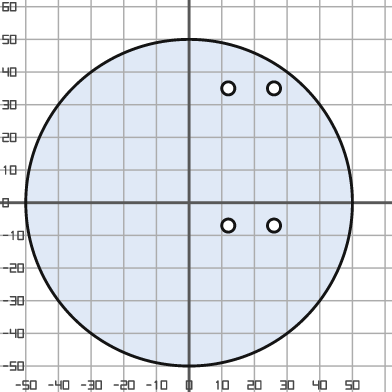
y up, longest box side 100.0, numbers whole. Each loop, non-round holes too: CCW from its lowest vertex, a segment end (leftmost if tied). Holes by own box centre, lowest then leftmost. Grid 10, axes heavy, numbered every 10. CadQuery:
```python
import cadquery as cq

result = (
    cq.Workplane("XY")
    .moveTo(0.0, 0.0)
    .circle(50.0)
    .moveTo(12.0, -7.0)
    .circle(2.0)
    .moveTo(26.0, -7.0)
    .circle(2.0)
    .moveTo(12.0, 35.0)
    .circle(2.0)
    .moveTo(26.0, 35.0)
    .circle(2.0)
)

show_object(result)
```